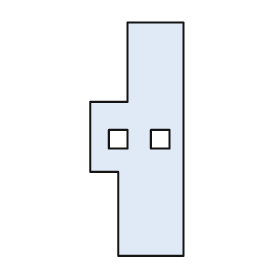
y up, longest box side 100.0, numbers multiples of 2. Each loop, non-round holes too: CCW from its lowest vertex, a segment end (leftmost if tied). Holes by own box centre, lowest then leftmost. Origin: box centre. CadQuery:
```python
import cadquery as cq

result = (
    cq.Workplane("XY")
    .moveTo(-8.0, -50.0)
    .lineTo(20.0, -50.0)
    .lineTo(20.0, 50.0)
    .lineTo(-4.0, 50.0)
    .lineTo(-4.0, 16.0)
    .lineTo(-20.0, 16.0)
    .lineTo(-20.0, -14.0)
    .lineTo(-8.0, -14.0)
    .close()
    .moveTo(-12.0, -4.0)
    .lineTo(-4.0, -4.0)
    .lineTo(-4.0, 4.0)
    .lineTo(-12.0, 4.0)
    .close()
    .moveTo(6.0, -4.0)
    .lineTo(14.0, -4.0)
    .lineTo(14.0, 4.0)
    .lineTo(6.0, 4.0)
    .close()
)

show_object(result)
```